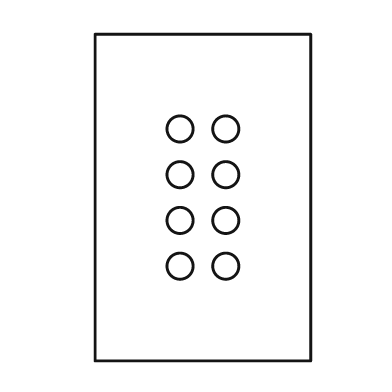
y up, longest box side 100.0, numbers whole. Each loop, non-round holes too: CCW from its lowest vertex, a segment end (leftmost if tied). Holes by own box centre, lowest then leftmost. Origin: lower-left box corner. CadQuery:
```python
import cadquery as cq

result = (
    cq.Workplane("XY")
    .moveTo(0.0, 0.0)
    .lineTo(66.0, 0.0)
    .lineTo(66.0, 100.0)
    .lineTo(0.0, 100.0)
    .close()
    .moveTo(26.0, 29.0)
    .circle(4.0)
    .moveTo(40.0, 29.0)
    .circle(4.0)
    .moveTo(26.0, 43.0)
    .circle(4.0)
    .moveTo(40.0, 43.0)
    .circle(4.0)
    .moveTo(26.0, 57.0)
    .circle(4.0)
    .moveTo(40.0, 57.0)
    .circle(4.0)
    .moveTo(26.0, 71.0)
    .circle(4.0)
    .moveTo(40.0, 71.0)
    .circle(4.0)
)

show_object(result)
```